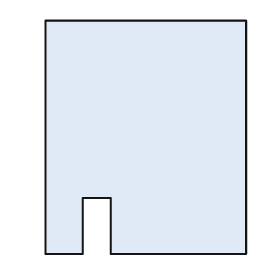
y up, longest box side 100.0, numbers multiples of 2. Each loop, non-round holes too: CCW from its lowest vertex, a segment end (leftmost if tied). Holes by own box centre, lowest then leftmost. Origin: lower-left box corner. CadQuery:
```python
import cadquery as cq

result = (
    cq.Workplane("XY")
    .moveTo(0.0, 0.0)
    .lineTo(16.0, 0.0)
    .lineTo(16.0, 24.0)
    .lineTo(28.0, 24.0)
    .lineTo(28.0, 0.0)
    .lineTo(86.0, 0.0)
    .lineTo(86.0, 100.0)
    .lineTo(0.0, 100.0)
    .close()
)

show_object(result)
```